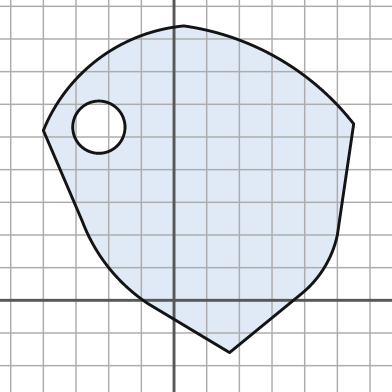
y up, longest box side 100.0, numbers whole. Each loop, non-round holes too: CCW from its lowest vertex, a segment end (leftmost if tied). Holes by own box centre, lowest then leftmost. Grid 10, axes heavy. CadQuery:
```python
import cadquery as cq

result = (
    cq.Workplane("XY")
    .moveTo(17.0, -16.0)
    .lineTo(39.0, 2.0)
    .threePointArc((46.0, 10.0), (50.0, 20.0))
    .lineTo(55.0, 54.0)
    .threePointArc((32.0, 74.0), (3.0, 84.0))
    .threePointArc((-23.0, 74.0), (-40.0, 52.0))
    .lineTo(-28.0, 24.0)
    .threePointArc((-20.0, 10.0), (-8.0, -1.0))
    .close()
    .moveTo(-23.0, 53.0)
    .circle(8.0)
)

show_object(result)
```